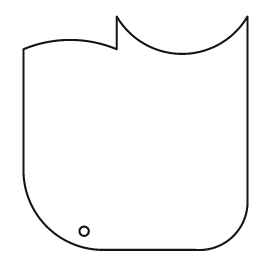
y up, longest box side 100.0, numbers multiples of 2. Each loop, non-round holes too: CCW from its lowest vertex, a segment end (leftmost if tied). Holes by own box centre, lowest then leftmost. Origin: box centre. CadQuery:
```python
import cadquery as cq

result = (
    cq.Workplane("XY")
    .moveTo(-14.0, -50.0)
    .lineTo(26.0, -50.0)
    .threePointArc((42.0, -44.0), (48.0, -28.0))
    .lineTo(48.0, 50.0)
    .threePointArc((20.0, 34.0), (-8.0, 50.0))
    .lineTo(-8.0, 36.0)
    .threePointArc((-28.0, 40.0), (-48.0, 36.0))
    .lineTo(-48.0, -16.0)
    .threePointArc((-38.0, -40.0), (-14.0, -50.0))
    .close()
    .moveTo(-22.0, -42.0)
    .circle(2.0)
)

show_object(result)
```